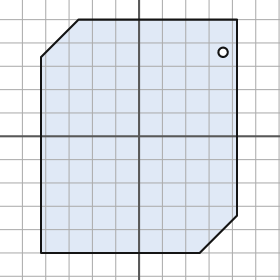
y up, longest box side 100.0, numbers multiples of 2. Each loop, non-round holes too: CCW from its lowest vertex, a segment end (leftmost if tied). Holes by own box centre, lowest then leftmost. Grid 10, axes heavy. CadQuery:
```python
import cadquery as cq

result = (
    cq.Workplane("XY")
    .moveTo(-42.0, -50.0)
    .lineTo(26.0, -50.0)
    .lineTo(42.0, -34.0)
    .lineTo(42.0, 50.0)
    .lineTo(-26.0, 50.0)
    .lineTo(-42.0, 34.0)
    .close()
    .moveTo(36.0, 36.0)
    .circle(2.0)
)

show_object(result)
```